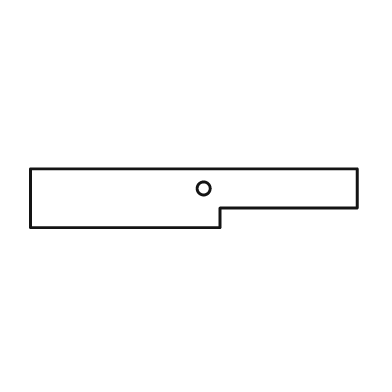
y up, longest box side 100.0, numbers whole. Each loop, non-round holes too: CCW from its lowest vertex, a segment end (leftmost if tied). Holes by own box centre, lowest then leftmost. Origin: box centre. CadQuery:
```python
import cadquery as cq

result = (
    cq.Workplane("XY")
    .moveTo(-50.0, -9.0)
    .lineTo(8.0, -9.0)
    .lineTo(8.0, -3.0)
    .lineTo(50.0, -3.0)
    .lineTo(50.0, 9.0)
    .lineTo(-50.0, 9.0)
    .close()
    .moveTo(3.0, 3.0)
    .circle(2.0)
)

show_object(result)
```